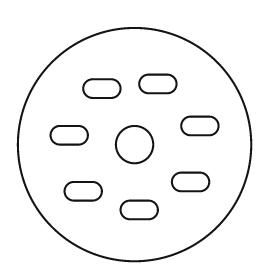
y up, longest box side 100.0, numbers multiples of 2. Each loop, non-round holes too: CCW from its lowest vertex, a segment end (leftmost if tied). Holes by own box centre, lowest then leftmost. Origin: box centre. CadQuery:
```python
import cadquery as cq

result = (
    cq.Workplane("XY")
    .moveTo(0.0, 0.0)
    .circle(50.0)
    .moveTo(-2.0, -32.0)
    .lineTo(6.0, -32.0)
    .threePointArc((10.0, -28.0), (6.0, -24.0))
    .lineTo(-2.0, -24.0)
    .threePointArc((-6.0, -28.0), (-2.0, -32.0))
    .close()
    .moveTo(-26.0, -24.0)
    .lineTo(-18.0, -24.0)
    .threePointArc((-14.0, -20.0), (-18.0, -16.0))
    .lineTo(-26.0, -16.0)
    .threePointArc((-30.0, -20.0), (-26.0, -24.0))
    .close()
    .moveTo(20.0, -20.0)
    .lineTo(28.0, -20.0)
    .threePointArc((32.0, -16.0), (28.0, -12.0))
    .lineTo(20.0, -12.0)
    .threePointArc((16.0, -16.0), (20.0, -20.0))
    .close()
    .moveTo(0.0, 0.0)
    .circle(8.0)
    .moveTo(-32.0, 0.0)
    .lineTo(-24.0, 0.0)
    .threePointArc((-20.0, 4.0), (-24.0, 8.0))
    .lineTo(-32.0, 8.0)
    .threePointArc((-36.0, 4.0), (-32.0, 0.0))
    .close()
    .moveTo(24.0, 4.0)
    .lineTo(32.0, 4.0)
    .threePointArc((36.0, 8.0), (32.0, 12.0))
    .lineTo(24.0, 12.0)
    .threePointArc((20.0, 8.0), (24.0, 4.0))
    .close()
    .moveTo(-18.0, 20.0)
    .lineTo(-10.0, 20.0)
    .threePointArc((-6.0, 24.0), (-10.0, 28.0))
    .lineTo(-18.0, 28.0)
    .threePointArc((-22.0, 24.0), (-18.0, 20.0))
    .close()
    .moveTo(6.0, 22.0)
    .lineTo(14.0, 22.0)
    .threePointArc((18.0, 26.0), (14.0, 30.0))
    .lineTo(6.0, 30.0)
    .threePointArc((2.0, 26.0), (6.0, 22.0))
    .close()
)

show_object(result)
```